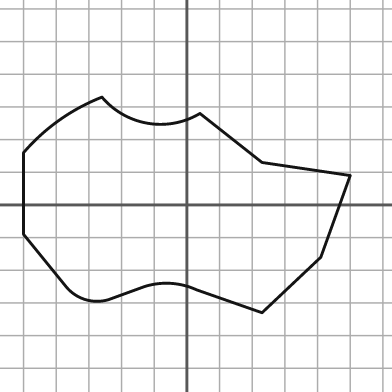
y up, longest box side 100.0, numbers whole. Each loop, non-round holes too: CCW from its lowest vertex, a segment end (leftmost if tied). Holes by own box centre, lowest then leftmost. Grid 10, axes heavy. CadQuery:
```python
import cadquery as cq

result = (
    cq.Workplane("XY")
    .moveTo(23.0, -33.0)
    .lineTo(41.0, -16.0)
    .lineTo(50.0, 9.0)
    .lineTo(23.0, 13.0)
    .lineTo(4.0, 28.0)
    .threePointArc((-12.0, 25.0), (-26.0, 33.0))
    .threePointArc((-39.0, 26.0), (-50.0, 16.0))
    .lineTo(-50.0, -9.0)
    .lineTo(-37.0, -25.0)
    .threePointArc((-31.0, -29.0), (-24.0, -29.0))
    .lineTo(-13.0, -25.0)
    .threePointArc((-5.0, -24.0), (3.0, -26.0))
    .close()
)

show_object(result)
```